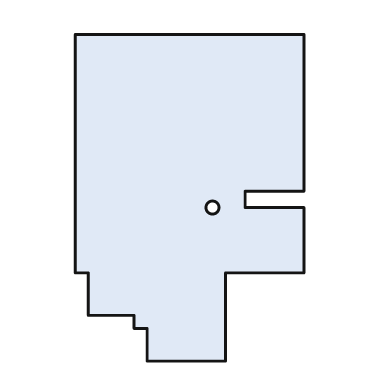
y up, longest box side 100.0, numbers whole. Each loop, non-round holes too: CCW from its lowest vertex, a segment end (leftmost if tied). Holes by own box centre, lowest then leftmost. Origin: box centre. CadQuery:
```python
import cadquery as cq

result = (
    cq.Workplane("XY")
    .moveTo(-13.0, -50.0)
    .lineTo(11.0, -50.0)
    .lineTo(11.0, -23.0)
    .lineTo(35.0, -23.0)
    .lineTo(35.0, -3.0)
    .lineTo(17.0, -3.0)
    .lineTo(17.0, 2.0)
    .lineTo(35.0, 2.0)
    .lineTo(35.0, 50.0)
    .lineTo(-35.0, 50.0)
    .lineTo(-35.0, -23.0)
    .lineTo(-31.0, -23.0)
    .lineTo(-31.0, -36.0)
    .lineTo(-17.0, -36.0)
    .lineTo(-17.0, -40.0)
    .lineTo(-13.0, -40.0)
    .close()
    .moveTo(7.0, -3.0)
    .circle(2.0)
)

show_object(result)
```